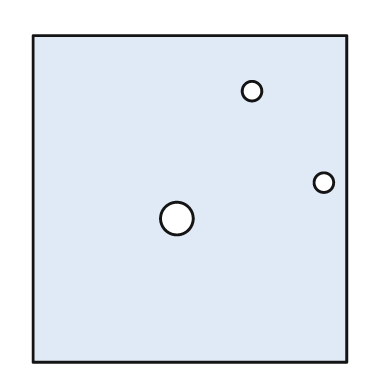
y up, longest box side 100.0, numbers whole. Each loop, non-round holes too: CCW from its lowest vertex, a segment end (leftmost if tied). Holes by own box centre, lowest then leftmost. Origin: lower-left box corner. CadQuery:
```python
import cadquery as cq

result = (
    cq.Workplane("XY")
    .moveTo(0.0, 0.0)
    .lineTo(96.0, 0.0)
    .lineTo(96.0, 100.0)
    .lineTo(0.0, 100.0)
    .close()
    .moveTo(44.0, 44.0)
    .circle(5.0)
    .moveTo(89.0, 55.0)
    .circle(3.0)
    .moveTo(67.0, 83.0)
    .circle(3.0)
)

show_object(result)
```